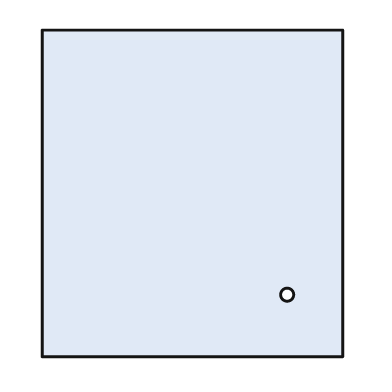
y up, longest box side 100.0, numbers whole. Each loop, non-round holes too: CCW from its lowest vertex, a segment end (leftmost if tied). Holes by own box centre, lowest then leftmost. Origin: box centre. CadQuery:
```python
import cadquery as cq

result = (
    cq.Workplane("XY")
    .moveTo(-46.0, -50.0)
    .lineTo(46.0, -50.0)
    .lineTo(46.0, 50.0)
    .lineTo(-46.0, 50.0)
    .close()
    .moveTo(29.0, -31.0)
    .circle(2.0)
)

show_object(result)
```